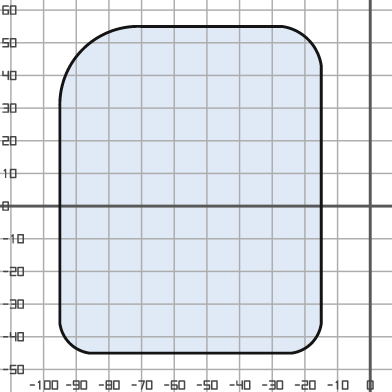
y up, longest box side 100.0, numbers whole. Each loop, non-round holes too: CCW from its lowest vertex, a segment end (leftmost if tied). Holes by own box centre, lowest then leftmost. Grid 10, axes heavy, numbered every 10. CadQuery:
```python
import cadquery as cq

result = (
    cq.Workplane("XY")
    .moveTo(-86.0, -45.0)
    .lineTo(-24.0, -45.0)
    .threePointArc((-18.0, -42.0), (-15.0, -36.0))
    .lineTo(-15.0, 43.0)
    .threePointArc((-19.0, 51.0), (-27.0, 55.0))
    .lineTo(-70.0, 55.0)
    .threePointArc((-88.0, 48.0), (-95.0, 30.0))
    .lineTo(-95.0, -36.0)
    .threePointArc((-92.0, -42.0), (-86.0, -45.0))
    .close()
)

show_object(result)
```